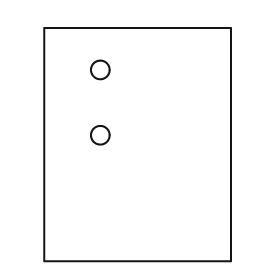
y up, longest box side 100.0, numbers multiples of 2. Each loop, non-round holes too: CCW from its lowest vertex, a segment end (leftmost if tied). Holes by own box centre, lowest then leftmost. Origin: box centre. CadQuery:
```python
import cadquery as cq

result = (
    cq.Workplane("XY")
    .moveTo(-40.0, -50.0)
    .lineTo(40.0, -50.0)
    .lineTo(40.0, 50.0)
    .lineTo(-40.0, 50.0)
    .close()
    .moveTo(-16.0, 4.0)
    .circle(4.0)
    .moveTo(-16.0, 32.0)
    .circle(4.0)
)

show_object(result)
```